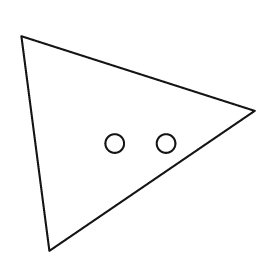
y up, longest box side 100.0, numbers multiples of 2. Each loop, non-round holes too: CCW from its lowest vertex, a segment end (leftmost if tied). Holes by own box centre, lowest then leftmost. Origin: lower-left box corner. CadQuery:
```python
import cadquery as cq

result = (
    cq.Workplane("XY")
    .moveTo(12.0, 0.0)
    .lineTo(100.0, 60.0)
    .lineTo(0.0, 92.0)
    .close()
    .moveTo(40.0, 46.0)
    .circle(4.0)
    .moveTo(62.0, 46.0)
    .circle(4.0)
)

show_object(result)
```